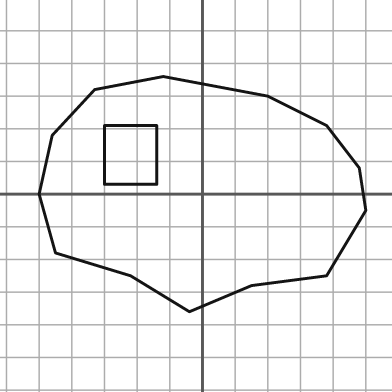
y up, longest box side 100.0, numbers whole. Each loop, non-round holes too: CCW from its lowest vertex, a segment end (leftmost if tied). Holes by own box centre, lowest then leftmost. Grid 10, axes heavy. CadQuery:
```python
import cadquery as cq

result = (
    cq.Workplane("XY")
    .moveTo(-4.0, -36.0)
    .lineTo(15.0, -28.0)
    .lineTo(38.0, -25.0)
    .lineTo(50.0, -5.0)
    .lineTo(48.0, 8.0)
    .lineTo(38.0, 21.0)
    .lineTo(20.0, 30.0)
    .lineTo(-12.0, 36.0)
    .lineTo(-33.0, 32.0)
    .lineTo(-46.0, 18.0)
    .lineTo(-50.0, 0.0)
    .lineTo(-45.0, -18.0)
    .lineTo(-22.0, -25.0)
    .close()
    .moveTo(-30.0, 3.0)
    .lineTo(-14.0, 3.0)
    .lineTo(-14.0, 21.0)
    .lineTo(-30.0, 21.0)
    .close()
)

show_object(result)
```